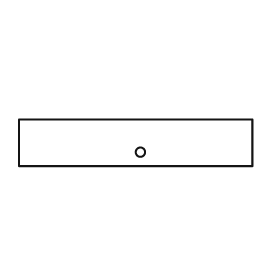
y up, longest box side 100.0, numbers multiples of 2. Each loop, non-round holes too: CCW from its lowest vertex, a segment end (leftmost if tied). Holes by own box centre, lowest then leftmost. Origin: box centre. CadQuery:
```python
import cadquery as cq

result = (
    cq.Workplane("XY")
    .moveTo(-50.0, -10.0)
    .lineTo(50.0, -10.0)
    .lineTo(50.0, 10.0)
    .lineTo(-50.0, 10.0)
    .close()
    .moveTo(2.0, -4.0)
    .circle(2.0)
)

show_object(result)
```